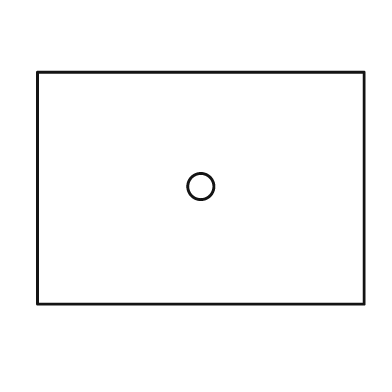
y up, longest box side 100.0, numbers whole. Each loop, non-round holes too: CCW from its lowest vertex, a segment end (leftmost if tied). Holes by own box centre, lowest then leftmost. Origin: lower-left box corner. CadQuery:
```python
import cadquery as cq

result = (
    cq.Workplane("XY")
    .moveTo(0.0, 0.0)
    .lineTo(100.0, 0.0)
    .lineTo(100.0, 71.0)
    .lineTo(0.0, 71.0)
    .close()
    .moveTo(50.0, 36.0)
    .circle(4.0)
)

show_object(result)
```